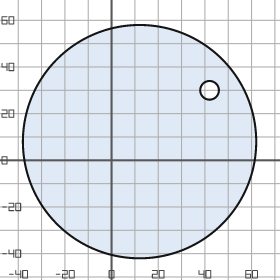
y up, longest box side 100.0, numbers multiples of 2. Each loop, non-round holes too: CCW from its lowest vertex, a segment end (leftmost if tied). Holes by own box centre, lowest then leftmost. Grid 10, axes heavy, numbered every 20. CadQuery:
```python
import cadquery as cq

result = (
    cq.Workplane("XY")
    .moveTo(12.0, 8.0)
    .circle(50.0)
    .moveTo(42.0, 30.0)
    .circle(4.0)
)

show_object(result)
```